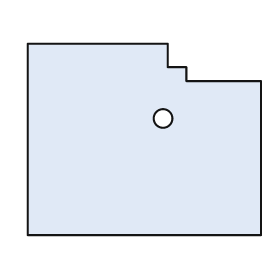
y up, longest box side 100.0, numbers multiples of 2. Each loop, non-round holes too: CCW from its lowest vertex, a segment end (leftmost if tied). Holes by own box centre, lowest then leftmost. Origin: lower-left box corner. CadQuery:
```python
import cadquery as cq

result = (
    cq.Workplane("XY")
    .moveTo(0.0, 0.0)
    .lineTo(100.0, 0.0)
    .lineTo(100.0, 66.0)
    .lineTo(68.0, 66.0)
    .lineTo(68.0, 72.0)
    .lineTo(60.0, 72.0)
    .lineTo(60.0, 82.0)
    .lineTo(0.0, 82.0)
    .close()
    .moveTo(58.0, 50.0)
    .circle(4.0)
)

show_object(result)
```